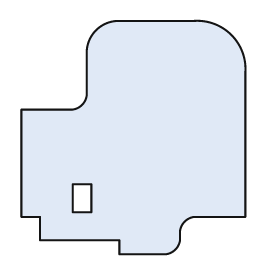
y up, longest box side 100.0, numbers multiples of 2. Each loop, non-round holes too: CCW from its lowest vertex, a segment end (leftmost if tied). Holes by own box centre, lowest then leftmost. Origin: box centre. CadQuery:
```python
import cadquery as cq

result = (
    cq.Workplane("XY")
    .moveTo(-6.0, -50.0)
    .lineTo(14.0, -50.0)
    .threePointArc((18.0, -48.0), (20.0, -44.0))
    .lineTo(20.0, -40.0)
    .threePointArc((22.0, -36.0), (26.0, -34.0))
    .lineTo(48.0, -34.0)
    .lineTo(48.0, 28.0)
    .threePointArc((42.0, 44.0), (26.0, 50.0))
    .lineTo(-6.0, 50.0)
    .threePointArc((-16.0, 46.0), (-20.0, 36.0))
    .lineTo(-20.0, 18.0)
    .threePointArc((-22.0, 14.0), (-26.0, 12.0))
    .lineTo(-48.0, 12.0)
    .lineTo(-48.0, -34.0)
    .lineTo(-40.0, -34.0)
    .lineTo(-40.0, -44.0)
    .lineTo(-6.0, -44.0)
    .close()
    .moveTo(-26.0, -32.0)
    .lineTo(-18.0, -32.0)
    .lineTo(-18.0, -20.0)
    .lineTo(-26.0, -20.0)
    .close()
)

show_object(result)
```